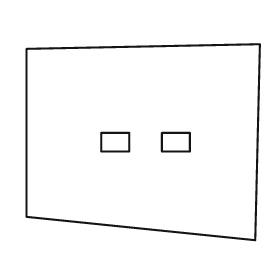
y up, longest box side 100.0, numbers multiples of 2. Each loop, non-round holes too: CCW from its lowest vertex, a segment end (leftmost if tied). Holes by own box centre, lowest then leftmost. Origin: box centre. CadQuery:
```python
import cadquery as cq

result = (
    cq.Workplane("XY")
    .moveTo(48.0, -42.0)
    .lineTo(50.0, 42.0)
    .lineTo(-50.0, 40.0)
    .lineTo(-50.0, -32.0)
    .close()
    .moveTo(-18.0, -4.0)
    .lineTo(-6.0, -4.0)
    .lineTo(-6.0, 4.0)
    .lineTo(-18.0, 4.0)
    .close()
    .moveTo(8.0, -4.0)
    .lineTo(20.0, -4.0)
    .lineTo(20.0, 4.0)
    .lineTo(8.0, 4.0)
    .close()
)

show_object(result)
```